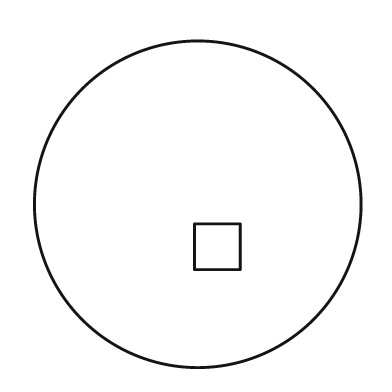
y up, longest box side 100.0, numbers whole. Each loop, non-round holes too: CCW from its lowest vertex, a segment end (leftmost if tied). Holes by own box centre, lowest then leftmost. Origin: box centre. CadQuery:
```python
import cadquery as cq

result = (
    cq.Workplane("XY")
    .moveTo(0.0, 0.0)
    .circle(50.0)
    .moveTo(-1.0, -20.0)
    .lineTo(13.0, -20.0)
    .lineTo(13.0, -6.0)
    .lineTo(-1.0, -6.0)
    .close()
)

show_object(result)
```